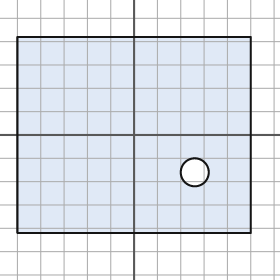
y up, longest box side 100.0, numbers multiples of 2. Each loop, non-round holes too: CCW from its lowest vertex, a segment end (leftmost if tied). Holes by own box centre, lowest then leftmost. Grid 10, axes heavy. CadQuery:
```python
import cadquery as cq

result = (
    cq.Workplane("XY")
    .moveTo(-50.0, -42.0)
    .lineTo(50.0, -42.0)
    .lineTo(50.0, 42.0)
    .lineTo(-50.0, 42.0)
    .close()
    .moveTo(26.0, -16.0)
    .circle(6.0)
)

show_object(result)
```